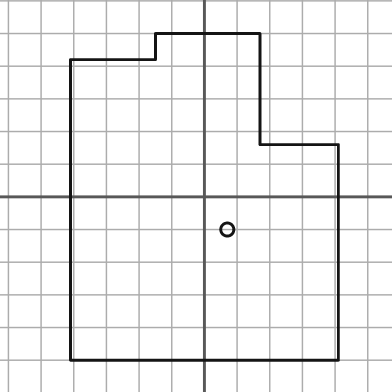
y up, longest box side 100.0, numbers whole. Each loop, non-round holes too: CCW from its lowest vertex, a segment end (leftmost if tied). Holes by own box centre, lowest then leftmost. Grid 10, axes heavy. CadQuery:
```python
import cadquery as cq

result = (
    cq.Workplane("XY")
    .moveTo(-41.0, -50.0)
    .lineTo(41.0, -50.0)
    .lineTo(41.0, 16.0)
    .lineTo(17.0, 16.0)
    .lineTo(17.0, 50.0)
    .lineTo(-15.0, 50.0)
    .lineTo(-15.0, 42.0)
    .lineTo(-41.0, 42.0)
    .close()
    .moveTo(7.0, -10.0)
    .circle(2.0)
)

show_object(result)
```